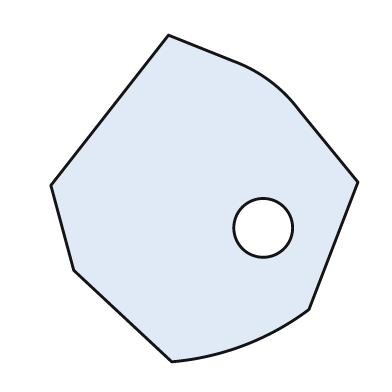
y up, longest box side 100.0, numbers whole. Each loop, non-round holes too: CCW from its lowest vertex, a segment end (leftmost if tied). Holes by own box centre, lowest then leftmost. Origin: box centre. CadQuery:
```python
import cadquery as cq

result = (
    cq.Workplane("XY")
    .moveTo(-10.0, -50.0)
    .threePointArc((12.0, -45.0), (32.0, -34.0))
    .lineTo(47.0, 5.0)
    .lineTo(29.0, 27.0)
    .threePointArc((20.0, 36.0), (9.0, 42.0))
    .lineTo(-11.0, 50.0)
    .lineTo(-47.0, 4.0)
    .lineTo(-40.0, -22.0)
    .close()
    .moveTo(18.0, -9.0)
    .circle(9.0)
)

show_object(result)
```